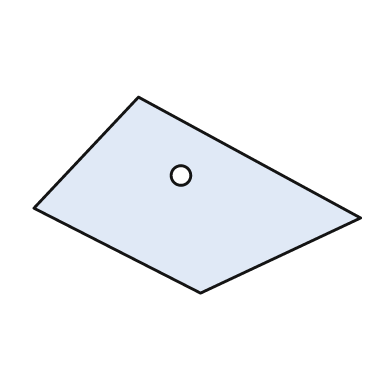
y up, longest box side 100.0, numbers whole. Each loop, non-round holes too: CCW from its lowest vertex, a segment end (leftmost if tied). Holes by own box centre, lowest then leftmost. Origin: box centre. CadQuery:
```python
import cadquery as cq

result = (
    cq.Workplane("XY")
    .moveTo(1.0, -30.0)
    .lineTo(50.0, -7.0)
    .lineTo(-18.0, 30.0)
    .lineTo(-50.0, -4.0)
    .close()
    .moveTo(-5.0, 6.0)
    .circle(3.0)
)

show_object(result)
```